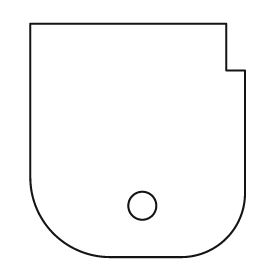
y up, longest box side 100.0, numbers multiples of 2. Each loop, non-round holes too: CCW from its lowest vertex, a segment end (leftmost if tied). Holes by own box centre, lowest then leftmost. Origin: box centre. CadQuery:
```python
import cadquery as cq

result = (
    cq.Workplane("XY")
    .moveTo(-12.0, -50.0)
    .lineTo(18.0, -50.0)
    .threePointArc((38.0, -42.0), (46.0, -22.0))
    .lineTo(46.0, 30.0)
    .lineTo(38.0, 30.0)
    .lineTo(38.0, 50.0)
    .lineTo(-46.0, 50.0)
    .lineTo(-46.0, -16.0)
    .threePointArc((-36.0, -40.0), (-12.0, -50.0))
    .close()
    .moveTo(2.0, -28.0)
    .circle(6.0)
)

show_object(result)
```